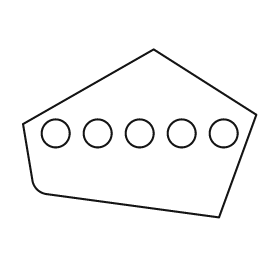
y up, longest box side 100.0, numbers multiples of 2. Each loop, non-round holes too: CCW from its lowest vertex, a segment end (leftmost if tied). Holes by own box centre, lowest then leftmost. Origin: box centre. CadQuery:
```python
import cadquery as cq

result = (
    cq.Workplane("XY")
    .moveTo(34.0, -36.0)
    .lineTo(50.0, 8.0)
    .lineTo(6.0, 36.0)
    .lineTo(-50.0, 4.0)
    .lineTo(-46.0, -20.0)
    .threePointArc((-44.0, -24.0), (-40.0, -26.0))
    .close()
    .moveTo(-36.0, 0.0)
    .circle(6.0)
    .moveTo(-18.0, 0.0)
    .circle(6.0)
    .moveTo(0.0, 0.0)
    .circle(6.0)
    .moveTo(18.0, 0.0)
    .circle(6.0)
    .moveTo(36.0, 0.0)
    .circle(6.0)
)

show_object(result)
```